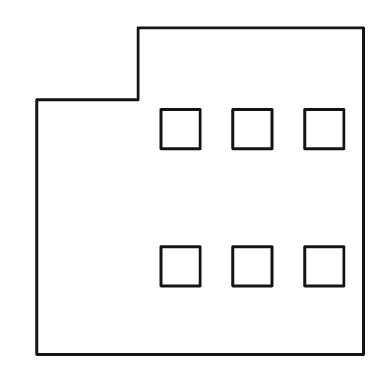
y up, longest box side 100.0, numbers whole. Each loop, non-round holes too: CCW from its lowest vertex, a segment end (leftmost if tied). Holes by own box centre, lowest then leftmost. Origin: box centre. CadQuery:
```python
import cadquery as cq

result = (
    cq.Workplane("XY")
    .moveTo(-50.0, -50.0)
    .lineTo(50.0, -50.0)
    .lineTo(50.0, 50.0)
    .lineTo(-19.0, 50.0)
    .lineTo(-19.0, 28.0)
    .lineTo(-50.0, 28.0)
    .close()
    .moveTo(-12.0, -29.0)
    .lineTo(0.0, -29.0)
    .lineTo(0.0, -17.0)
    .lineTo(-12.0, -17.0)
    .close()
    .moveTo(10.0, -29.0)
    .lineTo(22.0, -29.0)
    .lineTo(22.0, -17.0)
    .lineTo(10.0, -17.0)
    .close()
    .moveTo(32.0, -29.0)
    .lineTo(44.0, -29.0)
    .lineTo(44.0, -17.0)
    .lineTo(32.0, -17.0)
    .close()
    .moveTo(-12.0, 13.0)
    .lineTo(0.0, 13.0)
    .lineTo(0.0, 25.0)
    .lineTo(-12.0, 25.0)
    .close()
    .moveTo(10.0, 13.0)
    .lineTo(22.0, 13.0)
    .lineTo(22.0, 25.0)
    .lineTo(10.0, 25.0)
    .close()
    .moveTo(32.0, 13.0)
    .lineTo(44.0, 13.0)
    .lineTo(44.0, 25.0)
    .lineTo(32.0, 25.0)
    .close()
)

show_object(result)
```